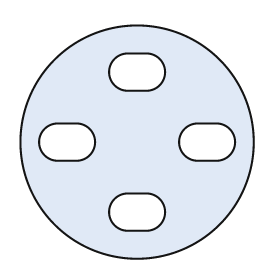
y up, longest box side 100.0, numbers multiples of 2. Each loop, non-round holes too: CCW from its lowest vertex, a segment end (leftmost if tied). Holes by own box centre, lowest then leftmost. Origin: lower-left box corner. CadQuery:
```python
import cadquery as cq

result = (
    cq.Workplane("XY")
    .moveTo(50.0, 50.0)
    .circle(50.0)
    .moveTo(46.0, 12.0)
    .lineTo(54.0, 12.0)
    .threePointArc((62.0, 20.0), (54.0, 28.0))
    .lineTo(46.0, 28.0)
    .threePointArc((38.0, 20.0), (46.0, 12.0))
    .close()
    .moveTo(16.0, 42.0)
    .lineTo(24.0, 42.0)
    .threePointArc((32.0, 50.0), (24.0, 58.0))
    .lineTo(16.0, 58.0)
    .threePointArc((8.0, 50.0), (16.0, 42.0))
    .close()
    .moveTo(76.0, 42.0)
    .lineTo(84.0, 42.0)
    .threePointArc((92.0, 50.0), (84.0, 58.0))
    .lineTo(76.0, 58.0)
    .threePointArc((68.0, 50.0), (76.0, 42.0))
    .close()
    .moveTo(46.0, 72.0)
    .lineTo(54.0, 72.0)
    .threePointArc((62.0, 80.0), (54.0, 88.0))
    .lineTo(46.0, 88.0)
    .threePointArc((38.0, 80.0), (46.0, 72.0))
    .close()
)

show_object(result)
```